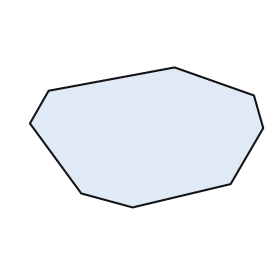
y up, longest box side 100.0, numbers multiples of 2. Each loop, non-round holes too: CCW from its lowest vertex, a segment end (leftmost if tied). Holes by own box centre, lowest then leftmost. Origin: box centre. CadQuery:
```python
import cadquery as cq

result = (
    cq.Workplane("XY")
    .moveTo(-6.0, -30.0)
    .lineTo(36.0, -20.0)
    .lineTo(50.0, 4.0)
    .lineTo(46.0, 18.0)
    .lineTo(12.0, 30.0)
    .lineTo(-42.0, 20.0)
    .lineTo(-50.0, 6.0)
    .lineTo(-28.0, -24.0)
    .close()
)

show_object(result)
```